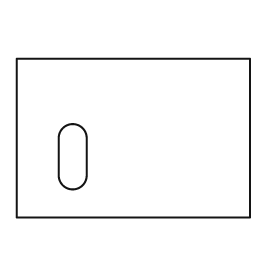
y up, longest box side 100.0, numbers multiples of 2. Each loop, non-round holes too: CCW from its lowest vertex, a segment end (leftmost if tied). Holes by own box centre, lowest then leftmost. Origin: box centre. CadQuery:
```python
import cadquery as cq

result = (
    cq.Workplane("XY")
    .moveTo(-50.0, -34.0)
    .lineTo(50.0, -34.0)
    .lineTo(50.0, 34.0)
    .lineTo(-50.0, 34.0)
    .close()
    .moveTo(-32.0, -16.0)
    .threePointArc((-26.0, -22.0), (-20.0, -16.0))
    .lineTo(-20.0, 0.0)
    .threePointArc((-26.0, 6.0), (-32.0, 0.0))
    .close()
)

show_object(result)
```